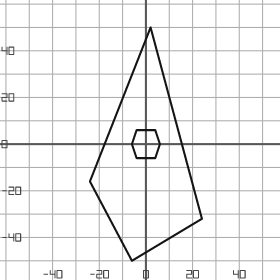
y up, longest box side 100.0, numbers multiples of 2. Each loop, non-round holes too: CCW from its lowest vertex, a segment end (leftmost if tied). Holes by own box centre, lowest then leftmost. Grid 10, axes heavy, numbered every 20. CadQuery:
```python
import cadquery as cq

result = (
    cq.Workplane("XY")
    .moveTo(-6.0, -50.0)
    .lineTo(24.0, -32.0)
    .lineTo(2.0, 50.0)
    .lineTo(-24.0, -16.0)
    .close()
    .moveTo(-4.0, -6.0)
    .lineTo(4.0, -6.0)
    .lineTo(6.0, 0.0)
    .lineTo(4.0, 6.0)
    .lineTo(-4.0, 6.0)
    .lineTo(-6.0, 0.0)
    .close()
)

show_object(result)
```